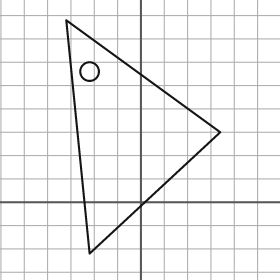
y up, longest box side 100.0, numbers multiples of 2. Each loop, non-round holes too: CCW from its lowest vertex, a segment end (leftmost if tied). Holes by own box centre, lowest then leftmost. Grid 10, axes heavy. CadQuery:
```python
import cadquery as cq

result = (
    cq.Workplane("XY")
    .moveTo(-22.0, -22.0)
    .lineTo(34.0, 30.0)
    .lineTo(-32.0, 78.0)
    .close()
    .moveTo(-22.0, 56.0)
    .circle(4.0)
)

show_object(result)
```